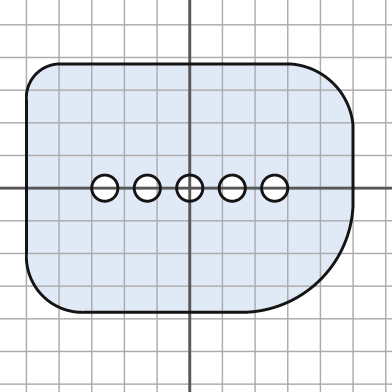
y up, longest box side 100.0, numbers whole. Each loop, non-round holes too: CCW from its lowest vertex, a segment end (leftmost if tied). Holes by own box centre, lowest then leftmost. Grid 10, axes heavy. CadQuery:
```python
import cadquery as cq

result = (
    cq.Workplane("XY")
    .moveTo(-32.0, -38.0)
    .lineTo(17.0, -38.0)
    .threePointArc((40.0, -28.0), (50.0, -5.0))
    .lineTo(50.0, 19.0)
    .threePointArc((44.0, 32.0), (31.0, 38.0))
    .lineTo(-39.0, 38.0)
    .threePointArc((-47.0, 35.0), (-50.0, 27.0))
    .lineTo(-50.0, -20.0)
    .threePointArc((-45.0, -33.0), (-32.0, -38.0))
    .close()
    .moveTo(-26.0, 0.0)
    .circle(4.0)
    .moveTo(-13.0, 0.0)
    .circle(4.0)
    .moveTo(0.0, 0.0)
    .circle(4.0)
    .moveTo(13.0, 0.0)
    .circle(4.0)
    .moveTo(26.0, 0.0)
    .circle(4.0)
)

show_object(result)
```